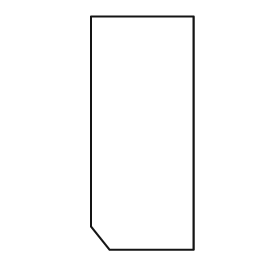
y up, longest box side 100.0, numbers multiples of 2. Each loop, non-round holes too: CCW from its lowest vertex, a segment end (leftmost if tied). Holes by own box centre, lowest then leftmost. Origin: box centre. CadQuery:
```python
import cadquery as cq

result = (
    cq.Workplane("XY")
    .moveTo(-14.0, -50.0)
    .lineTo(22.0, -50.0)
    .lineTo(22.0, 50.0)
    .lineTo(-22.0, 50.0)
    .lineTo(-22.0, -40.0)
    .close()
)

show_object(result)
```